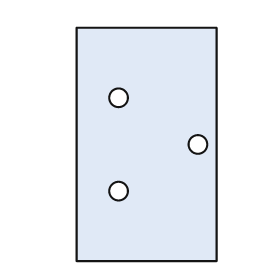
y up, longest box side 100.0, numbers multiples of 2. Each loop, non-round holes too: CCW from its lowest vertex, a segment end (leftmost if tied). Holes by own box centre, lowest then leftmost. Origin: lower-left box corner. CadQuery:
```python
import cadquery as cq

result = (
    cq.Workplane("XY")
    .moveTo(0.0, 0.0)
    .lineTo(60.0, 0.0)
    .lineTo(60.0, 100.0)
    .lineTo(0.0, 100.0)
    .close()
    .moveTo(18.0, 30.0)
    .circle(4.0)
    .moveTo(52.0, 50.0)
    .circle(4.0)
    .moveTo(18.0, 70.0)
    .circle(4.0)
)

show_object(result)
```